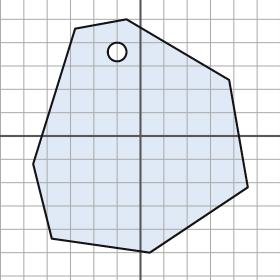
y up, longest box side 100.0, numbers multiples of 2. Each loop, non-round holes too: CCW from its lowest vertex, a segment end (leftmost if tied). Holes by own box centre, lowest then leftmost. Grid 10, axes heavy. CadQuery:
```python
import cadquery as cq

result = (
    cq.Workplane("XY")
    .moveTo(4.0, -50.0)
    .lineTo(46.0, -22.0)
    .lineTo(38.0, 24.0)
    .lineTo(-6.0, 50.0)
    .lineTo(-28.0, 46.0)
    .lineTo(-46.0, -12.0)
    .lineTo(-38.0, -44.0)
    .close()
    .moveTo(-10.0, 36.0)
    .circle(4.0)
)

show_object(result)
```